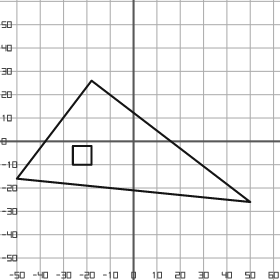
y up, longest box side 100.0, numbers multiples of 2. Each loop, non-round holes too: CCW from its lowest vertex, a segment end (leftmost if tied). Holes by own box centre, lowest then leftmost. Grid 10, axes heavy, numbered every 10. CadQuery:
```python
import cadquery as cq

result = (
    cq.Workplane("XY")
    .moveTo(50.0, -26.0)
    .lineTo(-18.0, 26.0)
    .lineTo(-50.0, -16.0)
    .close()
    .moveTo(-26.0, -10.0)
    .lineTo(-18.0, -10.0)
    .lineTo(-18.0, -2.0)
    .lineTo(-26.0, -2.0)
    .close()
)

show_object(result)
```